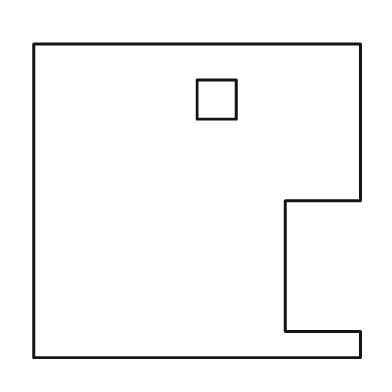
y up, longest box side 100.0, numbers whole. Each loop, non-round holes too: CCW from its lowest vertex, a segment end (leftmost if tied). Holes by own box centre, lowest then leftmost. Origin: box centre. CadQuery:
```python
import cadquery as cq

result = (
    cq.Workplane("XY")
    .moveTo(-50.0, -48.0)
    .lineTo(50.0, -48.0)
    .lineTo(50.0, -40.0)
    .lineTo(27.0, -40.0)
    .lineTo(27.0, 0.0)
    .lineTo(50.0, 0.0)
    .lineTo(50.0, 48.0)
    .lineTo(-50.0, 48.0)
    .close()
    .moveTo(0.0, 25.0)
    .lineTo(12.0, 25.0)
    .lineTo(12.0, 37.0)
    .lineTo(0.0, 37.0)
    .close()
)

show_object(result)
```